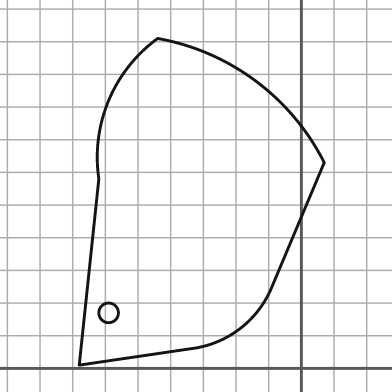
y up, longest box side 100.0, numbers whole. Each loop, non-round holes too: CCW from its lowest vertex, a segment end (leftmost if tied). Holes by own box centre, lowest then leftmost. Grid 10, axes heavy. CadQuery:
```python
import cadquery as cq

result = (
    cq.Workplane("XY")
    .moveTo(-68.0, 1.0)
    .lineTo(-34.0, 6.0)
    .threePointArc((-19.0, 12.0), (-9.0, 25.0))
    .lineTo(7.0, 63.0)
    .threePointArc((-14.0, 88.0), (-44.0, 101.0))
    .threePointArc((-59.0, 82.0), (-62.0, 58.0))
    .close()
    .moveTo(-59.0, 17.0)
    .circle(3.0)
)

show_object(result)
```